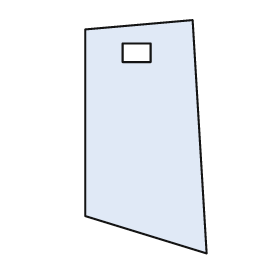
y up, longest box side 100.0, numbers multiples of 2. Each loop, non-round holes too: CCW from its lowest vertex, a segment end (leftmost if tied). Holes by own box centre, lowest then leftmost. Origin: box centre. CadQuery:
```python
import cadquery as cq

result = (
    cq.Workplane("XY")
    .moveTo(26.0, -50.0)
    .lineTo(20.0, 50.0)
    .lineTo(-26.0, 46.0)
    .lineTo(-26.0, -34.0)
    .close()
    .moveTo(-10.0, 32.0)
    .lineTo(2.0, 32.0)
    .lineTo(2.0, 40.0)
    .lineTo(-10.0, 40.0)
    .close()
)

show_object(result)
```